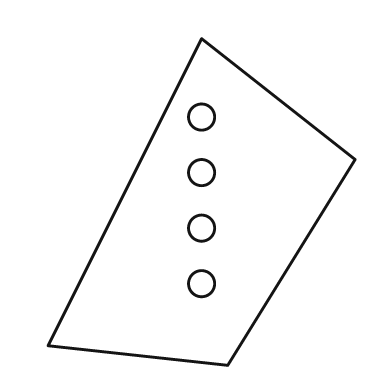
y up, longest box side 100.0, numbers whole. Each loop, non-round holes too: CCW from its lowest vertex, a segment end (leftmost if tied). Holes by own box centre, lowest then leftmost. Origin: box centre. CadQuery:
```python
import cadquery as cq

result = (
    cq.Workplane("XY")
    .moveTo(8.0, -50.0)
    .lineTo(47.0, 13.0)
    .lineTo(0.0, 50.0)
    .lineTo(-47.0, -44.0)
    .close()
    .moveTo(0.0, -25.0)
    .circle(4.0)
    .moveTo(0.0, -8.0)
    .circle(4.0)
    .moveTo(0.0, 9.0)
    .circle(4.0)
    .moveTo(0.0, 26.0)
    .circle(4.0)
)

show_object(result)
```